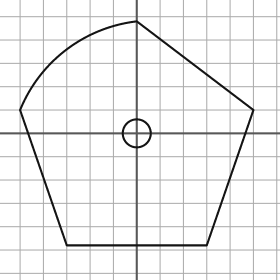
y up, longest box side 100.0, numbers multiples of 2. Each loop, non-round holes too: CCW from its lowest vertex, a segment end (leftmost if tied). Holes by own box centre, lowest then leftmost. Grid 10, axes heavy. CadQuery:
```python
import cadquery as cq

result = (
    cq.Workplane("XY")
    .moveTo(-30.0, -48.0)
    .lineTo(30.0, -48.0)
    .lineTo(50.0, 10.0)
    .lineTo(0.0, 48.0)
    .threePointArc((-30.0, 36.0), (-50.0, 10.0))
    .close()
    .moveTo(0.0, 0.0)
    .circle(6.0)
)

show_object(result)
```